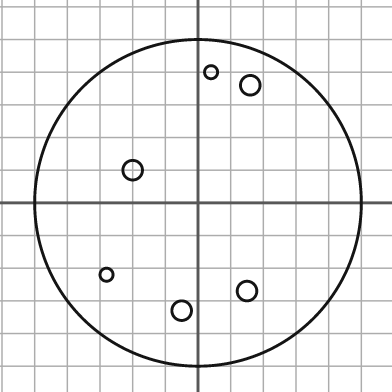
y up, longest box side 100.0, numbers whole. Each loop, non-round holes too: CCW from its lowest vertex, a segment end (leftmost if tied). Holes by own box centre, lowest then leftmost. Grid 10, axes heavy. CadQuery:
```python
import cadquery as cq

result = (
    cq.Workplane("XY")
    .moveTo(0.0, 0.0)
    .circle(50.0)
    .moveTo(-5.0, -33.0)
    .circle(3.0)
    .moveTo(15.0, -27.0)
    .circle(3.0)
    .moveTo(-28.0, -22.0)
    .circle(2.0)
    .moveTo(-20.0, 10.0)
    .circle(3.0)
    .moveTo(16.0, 36.0)
    .circle(3.0)
    .moveTo(4.0, 40.0)
    .circle(2.0)
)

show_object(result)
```